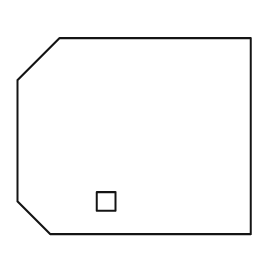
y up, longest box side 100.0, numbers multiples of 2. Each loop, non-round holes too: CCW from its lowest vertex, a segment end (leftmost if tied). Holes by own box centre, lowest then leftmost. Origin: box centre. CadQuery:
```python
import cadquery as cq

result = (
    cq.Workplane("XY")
    .moveTo(-36.0, -42.0)
    .lineTo(50.0, -42.0)
    .lineTo(50.0, 42.0)
    .lineTo(-32.0, 42.0)
    .lineTo(-50.0, 24.0)
    .lineTo(-50.0, -28.0)
    .close()
    .moveTo(-16.0, -32.0)
    .lineTo(-8.0, -32.0)
    .lineTo(-8.0, -24.0)
    .lineTo(-16.0, -24.0)
    .close()
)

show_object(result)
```